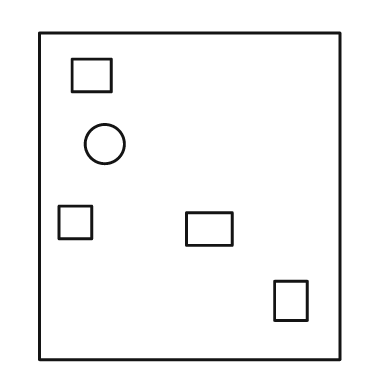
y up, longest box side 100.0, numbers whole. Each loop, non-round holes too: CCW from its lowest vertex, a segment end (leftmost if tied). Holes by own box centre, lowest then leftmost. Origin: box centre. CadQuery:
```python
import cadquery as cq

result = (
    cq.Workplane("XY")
    .moveTo(-46.0, -50.0)
    .lineTo(46.0, -50.0)
    .lineTo(46.0, 50.0)
    .lineTo(-46.0, 50.0)
    .close()
    .moveTo(26.0, -38.0)
    .lineTo(36.0, -38.0)
    .lineTo(36.0, -26.0)
    .lineTo(26.0, -26.0)
    .close()
    .moveTo(-1.0, -15.0)
    .lineTo(13.0, -15.0)
    .lineTo(13.0, -5.0)
    .lineTo(-1.0, -5.0)
    .close()
    .moveTo(-40.0, -13.0)
    .lineTo(-30.0, -13.0)
    .lineTo(-30.0, -3.0)
    .lineTo(-40.0, -3.0)
    .close()
    .moveTo(-26.0, 16.0)
    .circle(6.0)
    .moveTo(-36.0, 32.0)
    .lineTo(-24.0, 32.0)
    .lineTo(-24.0, 42.0)
    .lineTo(-36.0, 42.0)
    .close()
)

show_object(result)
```